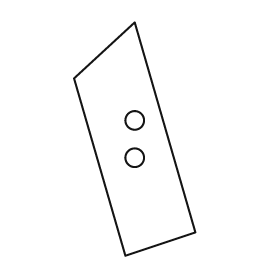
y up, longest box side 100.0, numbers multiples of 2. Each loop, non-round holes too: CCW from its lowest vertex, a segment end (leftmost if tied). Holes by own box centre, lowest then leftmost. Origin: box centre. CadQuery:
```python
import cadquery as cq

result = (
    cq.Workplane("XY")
    .moveTo(-4.0, -50.0)
    .lineTo(26.0, -40.0)
    .lineTo(0.0, 50.0)
    .lineTo(-26.0, 26.0)
    .close()
    .moveTo(0.0, -8.0)
    .circle(4.0)
    .moveTo(0.0, 8.0)
    .circle(4.0)
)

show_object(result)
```